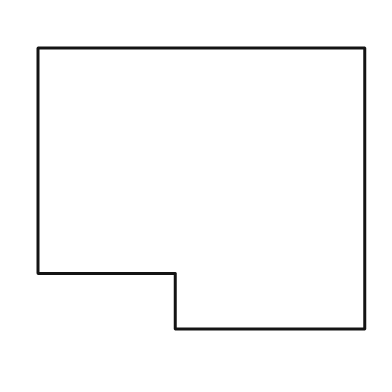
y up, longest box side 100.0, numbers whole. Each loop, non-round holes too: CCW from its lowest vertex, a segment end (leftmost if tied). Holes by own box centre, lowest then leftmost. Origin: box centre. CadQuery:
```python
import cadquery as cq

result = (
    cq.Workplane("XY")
    .moveTo(-8.0, -43.0)
    .lineTo(50.0, -43.0)
    .lineTo(50.0, 43.0)
    .lineTo(-50.0, 43.0)
    .lineTo(-50.0, -26.0)
    .lineTo(-8.0, -26.0)
    .close()
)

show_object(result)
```